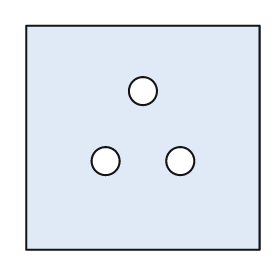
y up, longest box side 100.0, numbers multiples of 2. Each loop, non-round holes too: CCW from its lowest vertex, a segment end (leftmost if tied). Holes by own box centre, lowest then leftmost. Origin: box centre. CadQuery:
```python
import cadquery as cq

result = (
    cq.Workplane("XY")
    .moveTo(-50.0, -48.0)
    .lineTo(50.0, -48.0)
    .lineTo(50.0, 48.0)
    .lineTo(-50.0, 48.0)
    .close()
    .moveTo(-16.0, -10.0)
    .circle(6.0)
    .moveTo(16.0, -10.0)
    .circle(6.0)
    .moveTo(0.0, 20.0)
    .circle(6.0)
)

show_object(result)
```